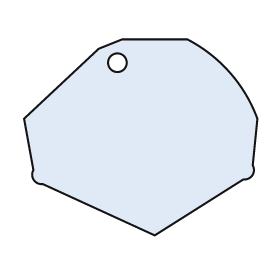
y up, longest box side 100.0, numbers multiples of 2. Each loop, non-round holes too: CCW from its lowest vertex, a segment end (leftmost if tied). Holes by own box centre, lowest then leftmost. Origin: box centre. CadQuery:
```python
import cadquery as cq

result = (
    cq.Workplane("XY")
    .moveTo(6.0, -42.0)
    .lineTo(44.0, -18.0)
    .threePointArc((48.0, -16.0), (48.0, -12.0))
    .lineTo(50.0, 8.0)
    .threePointArc((38.0, 28.0), (20.0, 42.0))
    .lineTo(-8.0, 42.0)
    .lineTo(-18.0, 38.0)
    .lineTo(-50.0, 8.0)
    .lineTo(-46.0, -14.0)
    .threePointArc((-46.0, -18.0), (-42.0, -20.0))
    .close()
    .moveTo(-10.0, 32.0)
    .circle(4.0)
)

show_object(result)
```